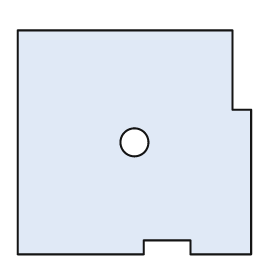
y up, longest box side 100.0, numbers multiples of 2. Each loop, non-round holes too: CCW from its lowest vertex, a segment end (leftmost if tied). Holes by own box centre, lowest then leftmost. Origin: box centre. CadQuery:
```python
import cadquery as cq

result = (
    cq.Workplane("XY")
    .moveTo(-50.0, -48.0)
    .lineTo(4.0, -48.0)
    .lineTo(4.0, -42.0)
    .lineTo(24.0, -42.0)
    .lineTo(24.0, -48.0)
    .lineTo(50.0, -48.0)
    .lineTo(50.0, 14.0)
    .lineTo(42.0, 14.0)
    .lineTo(42.0, 48.0)
    .lineTo(-50.0, 48.0)
    .close()
    .moveTo(0.0, 0.0)
    .circle(6.0)
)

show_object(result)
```